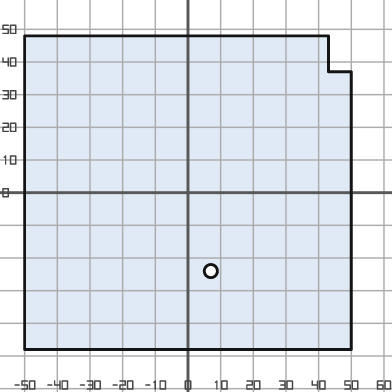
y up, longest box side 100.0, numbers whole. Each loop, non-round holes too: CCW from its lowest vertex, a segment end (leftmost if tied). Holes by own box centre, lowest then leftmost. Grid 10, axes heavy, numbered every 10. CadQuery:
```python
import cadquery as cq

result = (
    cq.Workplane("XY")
    .moveTo(-50.0, -48.0)
    .lineTo(50.0, -48.0)
    .lineTo(50.0, 37.0)
    .lineTo(43.0, 37.0)
    .lineTo(43.0, 48.0)
    .lineTo(-50.0, 48.0)
    .close()
    .moveTo(7.0, -24.0)
    .circle(2.0)
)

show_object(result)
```